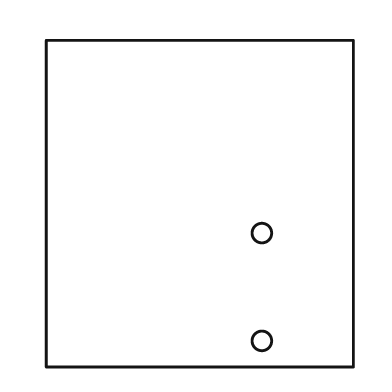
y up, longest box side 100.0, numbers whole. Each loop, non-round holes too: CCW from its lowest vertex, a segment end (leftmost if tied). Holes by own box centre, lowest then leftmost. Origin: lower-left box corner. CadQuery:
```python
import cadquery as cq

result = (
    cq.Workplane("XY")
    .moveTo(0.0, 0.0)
    .lineTo(94.0, 0.0)
    .lineTo(94.0, 100.0)
    .lineTo(0.0, 100.0)
    .close()
    .moveTo(66.0, 8.0)
    .circle(3.0)
    .moveTo(66.0, 41.0)
    .circle(3.0)
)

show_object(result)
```